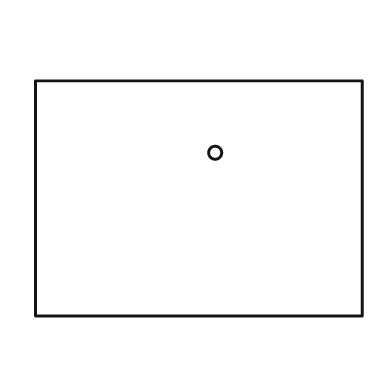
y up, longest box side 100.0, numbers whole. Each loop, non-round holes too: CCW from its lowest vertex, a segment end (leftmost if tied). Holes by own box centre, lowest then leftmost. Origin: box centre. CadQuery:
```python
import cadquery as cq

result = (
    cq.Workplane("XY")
    .moveTo(-50.0, -36.0)
    .lineTo(50.0, -36.0)
    .lineTo(50.0, 36.0)
    .lineTo(-50.0, 36.0)
    .close()
    .moveTo(5.0, 14.0)
    .circle(2.0)
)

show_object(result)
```